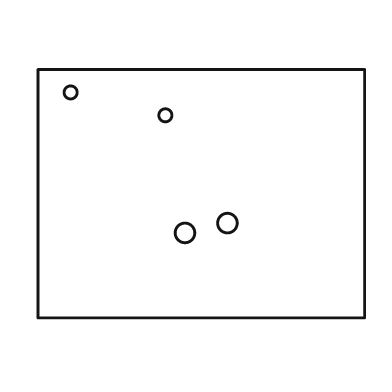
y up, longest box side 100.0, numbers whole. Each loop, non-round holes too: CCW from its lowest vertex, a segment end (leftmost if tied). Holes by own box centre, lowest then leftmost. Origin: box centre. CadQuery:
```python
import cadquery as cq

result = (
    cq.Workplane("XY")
    .moveTo(-50.0, -38.0)
    .lineTo(50.0, -38.0)
    .lineTo(50.0, 38.0)
    .lineTo(-50.0, 38.0)
    .close()
    .moveTo(-5.0, -12.0)
    .circle(3.0)
    .moveTo(8.0, -9.0)
    .circle(3.0)
    .moveTo(-11.0, 24.0)
    .circle(2.0)
    .moveTo(-40.0, 31.0)
    .circle(2.0)
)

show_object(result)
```